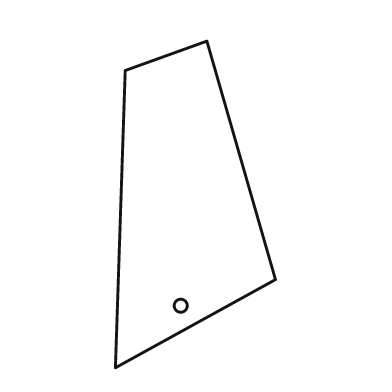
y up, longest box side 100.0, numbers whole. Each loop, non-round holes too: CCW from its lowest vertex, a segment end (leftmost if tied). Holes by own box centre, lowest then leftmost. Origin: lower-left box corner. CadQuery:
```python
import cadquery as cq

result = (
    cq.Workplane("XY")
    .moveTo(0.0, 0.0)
    .lineTo(49.0, 27.0)
    .lineTo(28.0, 100.0)
    .lineTo(3.0, 91.0)
    .close()
    .moveTo(20.0, 19.0)
    .circle(2.0)
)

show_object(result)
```